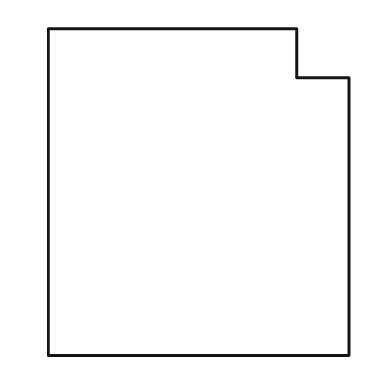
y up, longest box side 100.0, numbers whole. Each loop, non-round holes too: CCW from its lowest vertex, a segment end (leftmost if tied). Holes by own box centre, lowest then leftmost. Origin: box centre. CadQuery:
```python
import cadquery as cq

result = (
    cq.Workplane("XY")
    .moveTo(-46.0, -50.0)
    .lineTo(46.0, -50.0)
    .lineTo(46.0, 35.0)
    .lineTo(30.0, 35.0)
    .lineTo(30.0, 50.0)
    .lineTo(-46.0, 50.0)
    .close()
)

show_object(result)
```